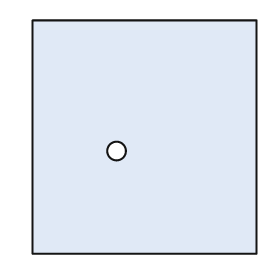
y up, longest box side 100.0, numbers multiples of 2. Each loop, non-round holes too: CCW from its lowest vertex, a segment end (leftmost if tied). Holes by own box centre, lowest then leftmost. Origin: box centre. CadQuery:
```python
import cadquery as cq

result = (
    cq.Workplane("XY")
    .moveTo(-48.0, -50.0)
    .lineTo(48.0, -50.0)
    .lineTo(48.0, 50.0)
    .lineTo(-48.0, 50.0)
    .close()
    .moveTo(-12.0, -6.0)
    .circle(4.0)
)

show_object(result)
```